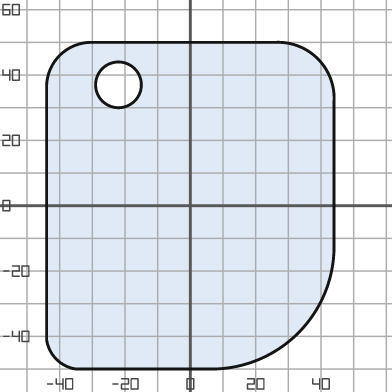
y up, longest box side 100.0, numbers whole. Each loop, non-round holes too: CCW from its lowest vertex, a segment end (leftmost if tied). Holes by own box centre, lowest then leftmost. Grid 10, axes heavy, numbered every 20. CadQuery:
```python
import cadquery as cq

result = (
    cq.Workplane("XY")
    .moveTo(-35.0, -50.0)
    .lineTo(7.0, -50.0)
    .threePointArc((33.0, -39.0), (44.0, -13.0))
    .lineTo(44.0, 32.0)
    .threePointArc((39.0, 45.0), (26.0, 50.0))
    .lineTo(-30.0, 50.0)
    .threePointArc((-40.0, 46.0), (-44.0, 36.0))
    .lineTo(-44.0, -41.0)
    .threePointArc((-41.0, -47.0), (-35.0, -50.0))
    .close()
    .moveTo(-22.0, 37.0)
    .circle(7.0)
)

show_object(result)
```